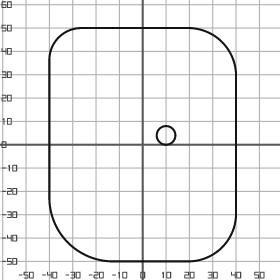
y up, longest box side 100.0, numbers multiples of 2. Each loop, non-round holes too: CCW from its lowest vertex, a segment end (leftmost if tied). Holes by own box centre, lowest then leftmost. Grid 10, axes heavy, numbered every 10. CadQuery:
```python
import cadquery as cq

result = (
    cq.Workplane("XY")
    .moveTo(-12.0, -50.0)
    .lineTo(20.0, -50.0)
    .threePointArc((34.0, -44.0), (40.0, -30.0))
    .lineTo(40.0, 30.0)
    .threePointArc((34.0, 44.0), (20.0, 50.0))
    .lineTo(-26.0, 50.0)
    .threePointArc((-36.0, 46.0), (-40.0, 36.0))
    .lineTo(-40.0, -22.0)
    .threePointArc((-32.0, -42.0), (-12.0, -50.0))
    .close()
    .moveTo(10.0, 4.0)
    .circle(4.0)
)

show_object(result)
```